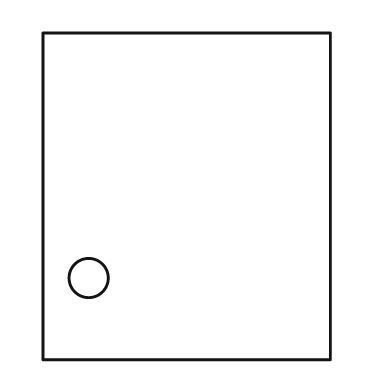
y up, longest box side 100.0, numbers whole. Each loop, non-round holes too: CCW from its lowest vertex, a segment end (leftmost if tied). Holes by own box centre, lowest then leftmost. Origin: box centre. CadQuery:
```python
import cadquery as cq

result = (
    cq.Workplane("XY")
    .moveTo(-44.0, -50.0)
    .lineTo(44.0, -50.0)
    .lineTo(44.0, 50.0)
    .lineTo(-44.0, 50.0)
    .close()
    .moveTo(-30.0, -25.0)
    .circle(6.0)
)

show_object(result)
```